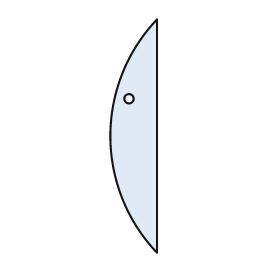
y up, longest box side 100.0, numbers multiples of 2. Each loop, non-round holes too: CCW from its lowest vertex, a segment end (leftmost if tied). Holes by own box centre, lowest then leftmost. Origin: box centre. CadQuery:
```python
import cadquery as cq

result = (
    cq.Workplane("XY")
    .moveTo(10.0, -50.0)
    .lineTo(10.0, 50.0)
    .threePointArc((-10.0, 0.0), (10.0, -50.0))
    .close()
    .moveTo(-2.0, 16.0)
    .circle(2.0)
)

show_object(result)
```